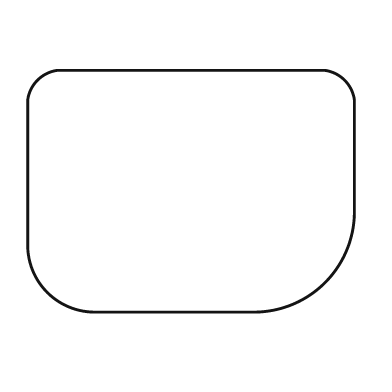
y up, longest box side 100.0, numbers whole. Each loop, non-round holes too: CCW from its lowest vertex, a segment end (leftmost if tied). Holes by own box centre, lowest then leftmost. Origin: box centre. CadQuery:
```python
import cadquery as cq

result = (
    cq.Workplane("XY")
    .moveTo(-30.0, -37.0)
    .lineTo(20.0, -37.0)
    .threePointArc((41.0, -28.0), (50.0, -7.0))
    .lineTo(50.0, 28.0)
    .threePointArc((47.0, 34.0), (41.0, 37.0))
    .lineTo(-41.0, 37.0)
    .threePointArc((-47.0, 34.0), (-50.0, 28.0))
    .lineTo(-50.0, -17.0)
    .threePointArc((-44.0, -31.0), (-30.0, -37.0))
    .close()
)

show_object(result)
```